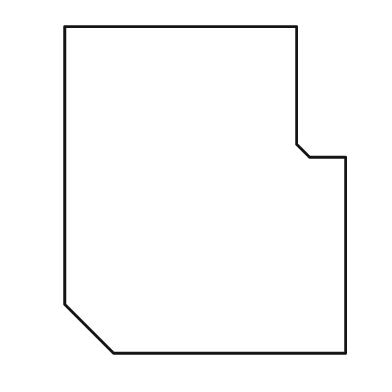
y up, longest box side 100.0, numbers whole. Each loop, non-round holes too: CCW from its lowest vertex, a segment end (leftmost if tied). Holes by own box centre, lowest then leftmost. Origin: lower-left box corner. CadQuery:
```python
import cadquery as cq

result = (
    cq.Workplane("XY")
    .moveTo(15.0, 0.0)
    .lineTo(86.0, 0.0)
    .lineTo(86.0, 60.0)
    .lineTo(75.0, 60.0)
    .lineTo(71.0, 64.0)
    .lineTo(71.0, 100.0)
    .lineTo(0.0, 100.0)
    .lineTo(0.0, 15.0)
    .close()
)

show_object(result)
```